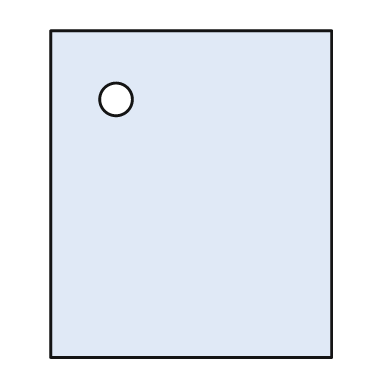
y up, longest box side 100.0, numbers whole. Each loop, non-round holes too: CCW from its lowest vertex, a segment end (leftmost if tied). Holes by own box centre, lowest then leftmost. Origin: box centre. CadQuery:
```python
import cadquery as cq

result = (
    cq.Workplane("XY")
    .moveTo(-43.0, -50.0)
    .lineTo(43.0, -50.0)
    .lineTo(43.0, 50.0)
    .lineTo(-43.0, 50.0)
    .close()
    .moveTo(-23.0, 29.0)
    .circle(5.0)
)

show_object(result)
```